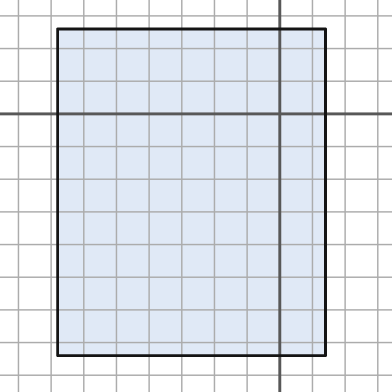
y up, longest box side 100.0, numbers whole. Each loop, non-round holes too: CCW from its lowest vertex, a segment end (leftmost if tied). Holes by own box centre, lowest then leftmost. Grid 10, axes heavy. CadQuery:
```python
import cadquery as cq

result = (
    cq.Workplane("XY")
    .moveTo(-68.0, -74.0)
    .lineTo(14.0, -74.0)
    .lineTo(14.0, 26.0)
    .lineTo(-68.0, 26.0)
    .close()
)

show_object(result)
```